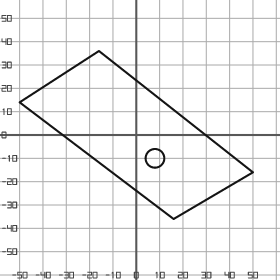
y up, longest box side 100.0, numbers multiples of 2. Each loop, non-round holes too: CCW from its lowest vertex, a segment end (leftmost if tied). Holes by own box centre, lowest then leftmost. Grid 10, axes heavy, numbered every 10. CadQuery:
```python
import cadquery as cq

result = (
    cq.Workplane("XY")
    .moveTo(16.0, -36.0)
    .lineTo(50.0, -16.0)
    .lineTo(-16.0, 36.0)
    .lineTo(-50.0, 14.0)
    .close()
    .moveTo(8.0, -10.0)
    .circle(4.0)
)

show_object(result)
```